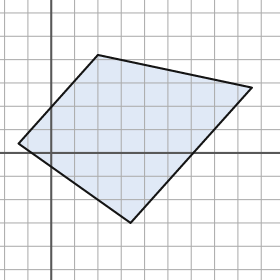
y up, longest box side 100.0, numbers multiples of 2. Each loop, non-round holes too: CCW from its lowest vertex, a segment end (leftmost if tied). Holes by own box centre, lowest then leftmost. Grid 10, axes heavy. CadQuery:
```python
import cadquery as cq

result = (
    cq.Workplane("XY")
    .moveTo(34.0, -30.0)
    .lineTo(86.0, 28.0)
    .lineTo(20.0, 42.0)
    .lineTo(-14.0, 4.0)
    .close()
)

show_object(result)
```